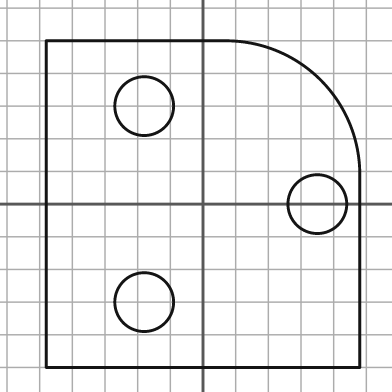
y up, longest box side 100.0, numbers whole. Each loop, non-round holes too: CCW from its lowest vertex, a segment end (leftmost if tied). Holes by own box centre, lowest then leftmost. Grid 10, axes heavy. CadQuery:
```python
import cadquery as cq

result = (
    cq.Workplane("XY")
    .moveTo(-48.0, -50.0)
    .lineTo(48.0, -50.0)
    .lineTo(48.0, 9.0)
    .threePointArc((36.0, 38.0), (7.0, 50.0))
    .lineTo(-48.0, 50.0)
    .close()
    .moveTo(-18.0, -30.0)
    .circle(9.0)
    .moveTo(35.0, 0.0)
    .circle(9.0)
    .moveTo(-18.0, 30.0)
    .circle(9.0)
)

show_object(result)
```